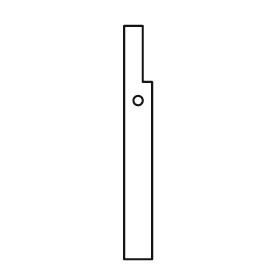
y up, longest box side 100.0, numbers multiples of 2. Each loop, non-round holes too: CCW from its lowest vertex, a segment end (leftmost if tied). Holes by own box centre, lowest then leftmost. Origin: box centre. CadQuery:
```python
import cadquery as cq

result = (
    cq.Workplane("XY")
    .moveTo(-6.0, -50.0)
    .lineTo(6.0, -50.0)
    .lineTo(6.0, 26.0)
    .lineTo(2.0, 26.0)
    .lineTo(2.0, 50.0)
    .lineTo(-6.0, 50.0)
    .close()
    .moveTo(0.0, 18.0)
    .circle(2.0)
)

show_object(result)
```